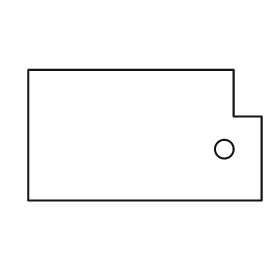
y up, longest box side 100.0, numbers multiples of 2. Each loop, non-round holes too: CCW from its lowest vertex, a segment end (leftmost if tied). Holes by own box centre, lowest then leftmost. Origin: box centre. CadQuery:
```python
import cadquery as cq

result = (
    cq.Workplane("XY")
    .moveTo(-50.0, -28.0)
    .lineTo(50.0, -28.0)
    .lineTo(50.0, 8.0)
    .lineTo(38.0, 8.0)
    .lineTo(38.0, 28.0)
    .lineTo(-50.0, 28.0)
    .close()
    .moveTo(34.0, -6.0)
    .circle(4.0)
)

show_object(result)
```